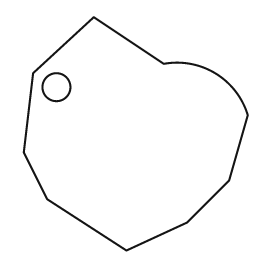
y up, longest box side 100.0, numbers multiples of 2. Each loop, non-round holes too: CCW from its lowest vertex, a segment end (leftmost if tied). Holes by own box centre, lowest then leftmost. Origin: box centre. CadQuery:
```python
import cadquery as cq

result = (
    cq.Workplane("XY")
    .moveTo(-4.0, -50.0)
    .lineTo(22.0, -38.0)
    .lineTo(40.0, -20.0)
    .lineTo(48.0, 8.0)
    .threePointArc((34.0, 26.0), (12.0, 30.0))
    .lineTo(-18.0, 50.0)
    .lineTo(-44.0, 26.0)
    .lineTo(-48.0, -8.0)
    .lineTo(-38.0, -28.0)
    .close()
    .moveTo(-34.0, 20.0)
    .circle(6.0)
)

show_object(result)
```